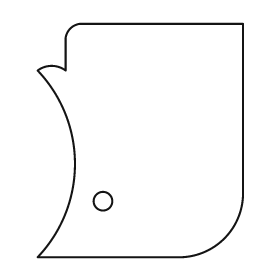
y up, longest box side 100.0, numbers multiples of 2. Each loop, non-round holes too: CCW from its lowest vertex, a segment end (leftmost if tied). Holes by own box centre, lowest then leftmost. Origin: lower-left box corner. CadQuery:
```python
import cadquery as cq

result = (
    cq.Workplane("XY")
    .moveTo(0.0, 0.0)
    .lineTo(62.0, 0.0)
    .threePointArc((80.0, 8.0), (88.0, 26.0))
    .lineTo(88.0, 100.0)
    .lineTo(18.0, 100.0)
    .threePointArc((14.0, 98.0), (12.0, 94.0))
    .lineTo(12.0, 80.0)
    .threePointArc((6.0, 82.0), (0.0, 80.0))
    .threePointArc((16.0, 40.0), (0.0, 0.0))
    .close()
    .moveTo(28.0, 24.0)
    .circle(4.0)
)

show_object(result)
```